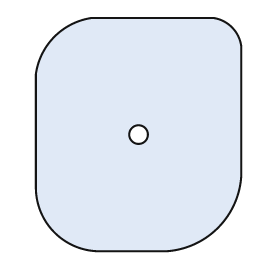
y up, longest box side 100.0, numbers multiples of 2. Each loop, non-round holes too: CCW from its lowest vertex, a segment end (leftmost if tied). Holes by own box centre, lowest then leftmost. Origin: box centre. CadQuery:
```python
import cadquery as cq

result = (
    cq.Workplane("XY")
    .moveTo(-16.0, -50.0)
    .lineTo(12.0, -50.0)
    .threePointArc((34.0, -40.0), (44.0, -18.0))
    .lineTo(44.0, 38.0)
    .threePointArc((40.0, 46.0), (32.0, 50.0))
    .lineTo(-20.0, 50.0)
    .threePointArc((-36.0, 42.0), (-44.0, 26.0))
    .lineTo(-44.0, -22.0)
    .threePointArc((-36.0, -42.0), (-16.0, -50.0))
    .close()
    .moveTo(0.0, 0.0)
    .circle(4.0)
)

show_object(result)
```